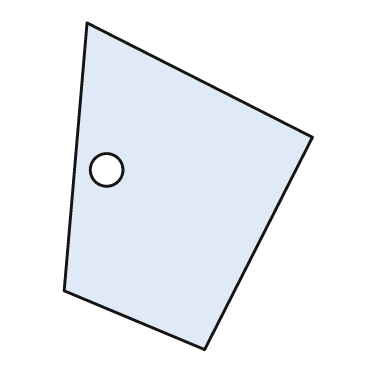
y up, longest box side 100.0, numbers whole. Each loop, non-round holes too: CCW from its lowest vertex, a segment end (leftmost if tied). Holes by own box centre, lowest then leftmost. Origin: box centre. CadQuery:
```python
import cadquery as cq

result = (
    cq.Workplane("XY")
    .moveTo(5.0, -50.0)
    .lineTo(38.0, 15.0)
    .lineTo(-31.0, 50.0)
    .lineTo(-38.0, -32.0)
    .close()
    .moveTo(-25.0, 5.0)
    .circle(5.0)
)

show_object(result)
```